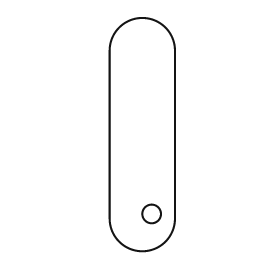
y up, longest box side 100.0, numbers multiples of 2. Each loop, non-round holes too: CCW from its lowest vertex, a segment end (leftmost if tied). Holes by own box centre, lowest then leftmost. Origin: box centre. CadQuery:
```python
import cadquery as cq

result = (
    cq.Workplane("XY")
    .moveTo(-14.0, -36.0)
    .threePointArc((0.0, -50.0), (14.0, -36.0))
    .lineTo(14.0, 36.0)
    .threePointArc((0.0, 50.0), (-14.0, 36.0))
    .close()
    .moveTo(4.0, -34.0)
    .circle(4.0)
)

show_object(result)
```